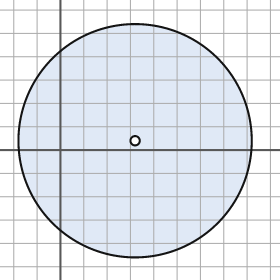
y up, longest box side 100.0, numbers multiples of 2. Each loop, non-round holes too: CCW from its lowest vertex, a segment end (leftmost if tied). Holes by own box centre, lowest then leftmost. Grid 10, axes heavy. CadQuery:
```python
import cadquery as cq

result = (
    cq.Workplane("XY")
    .moveTo(32.0, 4.0)
    .circle(50.0)
    .moveTo(32.0, 4.0)
    .circle(2.0)
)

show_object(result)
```